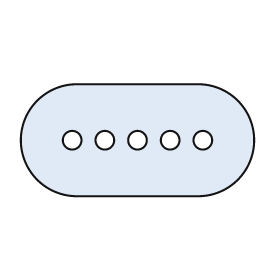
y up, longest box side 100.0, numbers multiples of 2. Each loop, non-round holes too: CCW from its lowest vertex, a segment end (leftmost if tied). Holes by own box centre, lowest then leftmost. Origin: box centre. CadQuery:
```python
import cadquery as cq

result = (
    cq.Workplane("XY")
    .moveTo(-26.0, -24.0)
    .lineTo(26.0, -24.0)
    .threePointArc((50.0, 0.0), (26.0, 24.0))
    .lineTo(-26.0, 24.0)
    .threePointArc((-50.0, 0.0), (-26.0, -24.0))
    .close()
    .moveTo(-28.0, 0.0)
    .circle(4.0)
    .moveTo(-14.0, 0.0)
    .circle(4.0)
    .moveTo(0.0, 0.0)
    .circle(4.0)
    .moveTo(14.0, 0.0)
    .circle(4.0)
    .moveTo(28.0, 0.0)
    .circle(4.0)
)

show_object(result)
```